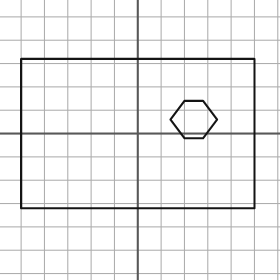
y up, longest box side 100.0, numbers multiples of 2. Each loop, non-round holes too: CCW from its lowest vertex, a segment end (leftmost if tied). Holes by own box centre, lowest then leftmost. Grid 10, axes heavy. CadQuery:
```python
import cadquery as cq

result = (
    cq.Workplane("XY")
    .moveTo(-50.0, -32.0)
    .lineTo(50.0, -32.0)
    .lineTo(50.0, 32.0)
    .lineTo(-50.0, 32.0)
    .close()
    .moveTo(20.0, -2.0)
    .lineTo(28.0, -2.0)
    .lineTo(34.0, 6.0)
    .lineTo(28.0, 14.0)
    .lineTo(20.0, 14.0)
    .lineTo(14.0, 6.0)
    .close()
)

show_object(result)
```